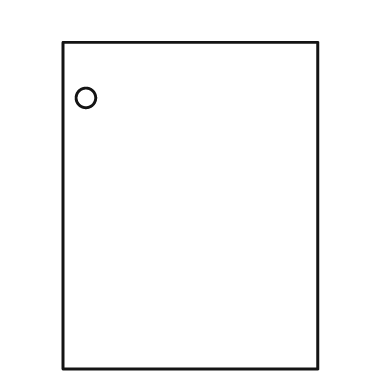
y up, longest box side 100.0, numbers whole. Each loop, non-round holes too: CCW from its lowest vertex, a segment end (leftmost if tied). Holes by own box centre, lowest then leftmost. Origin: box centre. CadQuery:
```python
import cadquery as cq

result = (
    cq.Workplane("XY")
    .moveTo(-39.0, -50.0)
    .lineTo(39.0, -50.0)
    .lineTo(39.0, 50.0)
    .lineTo(-39.0, 50.0)
    .close()
    .moveTo(-32.0, 33.0)
    .circle(3.0)
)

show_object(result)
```